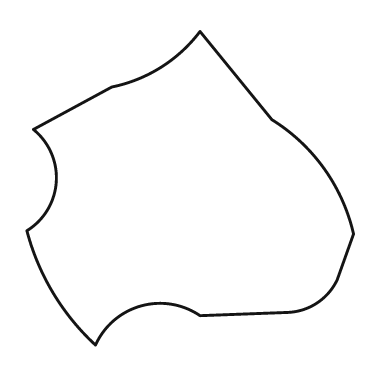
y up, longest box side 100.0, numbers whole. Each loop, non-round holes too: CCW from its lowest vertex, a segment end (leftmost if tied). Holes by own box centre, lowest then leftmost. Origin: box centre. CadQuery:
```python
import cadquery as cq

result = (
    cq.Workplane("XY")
    .moveTo(-29.0, -48.0)
    .threePointArc((-15.0, -36.0), (3.0, -39.0))
    .lineTo(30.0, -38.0)
    .threePointArc((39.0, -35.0), (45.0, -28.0))
    .lineTo(50.0, -14.0)
    .threePointArc((41.0, 6.0), (25.0, 21.0))
    .lineTo(3.0, 48.0)
    .threePointArc((-9.0, 37.0), (-24.0, 31.0))
    .lineTo(-48.0, 18.0)
    .threePointArc((-41.0, 2.0), (-50.0, -13.0))
    .threePointArc((-42.0, -32.0), (-29.0, -48.0))
    .close()
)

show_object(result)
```